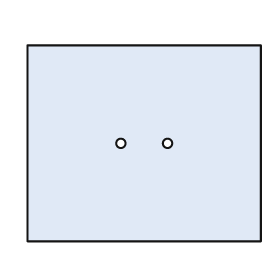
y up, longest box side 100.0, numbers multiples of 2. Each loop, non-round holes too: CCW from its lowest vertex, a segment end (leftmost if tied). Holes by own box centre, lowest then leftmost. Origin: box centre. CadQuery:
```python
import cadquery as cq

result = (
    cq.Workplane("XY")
    .moveTo(-50.0, -42.0)
    .lineTo(50.0, -42.0)
    .lineTo(50.0, 42.0)
    .lineTo(-50.0, 42.0)
    .close()
    .moveTo(-10.0, 0.0)
    .circle(2.0)
    .moveTo(10.0, 0.0)
    .circle(2.0)
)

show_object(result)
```